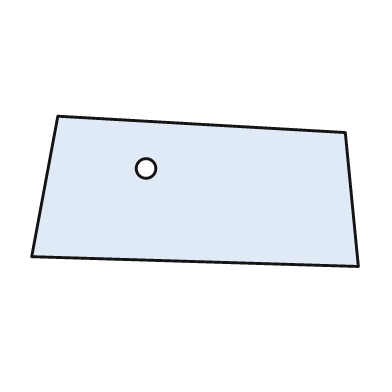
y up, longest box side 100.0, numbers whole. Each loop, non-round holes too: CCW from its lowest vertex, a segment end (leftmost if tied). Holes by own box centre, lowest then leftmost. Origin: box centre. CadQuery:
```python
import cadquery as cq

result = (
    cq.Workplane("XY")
    .moveTo(50.0, -23.0)
    .lineTo(46.0, 18.0)
    .lineTo(-42.0, 23.0)
    .lineTo(-50.0, -20.0)
    .close()
    .moveTo(-15.0, 7.0)
    .circle(3.0)
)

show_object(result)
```